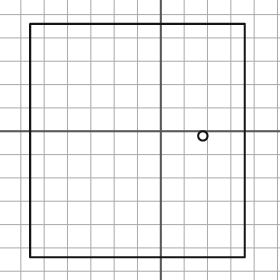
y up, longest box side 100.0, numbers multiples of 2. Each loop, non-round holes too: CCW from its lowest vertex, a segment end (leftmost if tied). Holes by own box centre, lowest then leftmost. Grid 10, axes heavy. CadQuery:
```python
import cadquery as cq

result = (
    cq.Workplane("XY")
    .moveTo(-56.0, -54.0)
    .lineTo(36.0, -54.0)
    .lineTo(36.0, 46.0)
    .lineTo(-56.0, 46.0)
    .close()
    .moveTo(18.0, -2.0)
    .circle(2.0)
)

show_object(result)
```